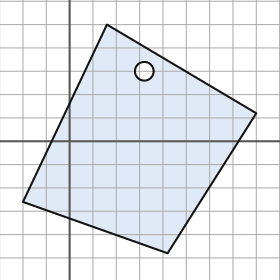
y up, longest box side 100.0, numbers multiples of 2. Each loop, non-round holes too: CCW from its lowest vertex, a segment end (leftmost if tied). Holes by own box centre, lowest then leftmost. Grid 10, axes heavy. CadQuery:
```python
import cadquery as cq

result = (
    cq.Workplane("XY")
    .moveTo(42.0, -48.0)
    .lineTo(80.0, 12.0)
    .lineTo(16.0, 50.0)
    .lineTo(-20.0, -26.0)
    .close()
    .moveTo(32.0, 30.0)
    .circle(4.0)
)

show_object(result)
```